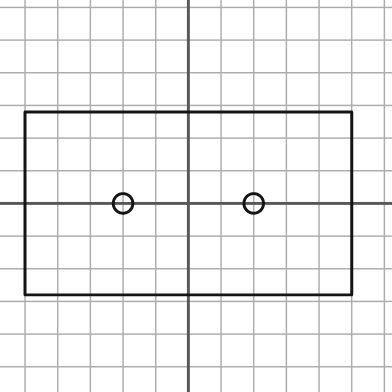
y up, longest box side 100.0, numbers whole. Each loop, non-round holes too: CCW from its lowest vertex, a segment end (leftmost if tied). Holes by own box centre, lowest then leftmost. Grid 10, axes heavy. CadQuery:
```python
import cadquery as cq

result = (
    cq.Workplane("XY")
    .moveTo(-50.0, -28.0)
    .lineTo(50.0, -28.0)
    .lineTo(50.0, 28.0)
    .lineTo(-50.0, 28.0)
    .close()
    .moveTo(-20.0, 0.0)
    .circle(3.0)
    .moveTo(20.0, 0.0)
    .circle(3.0)
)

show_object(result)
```